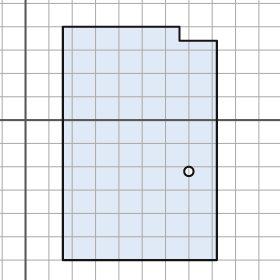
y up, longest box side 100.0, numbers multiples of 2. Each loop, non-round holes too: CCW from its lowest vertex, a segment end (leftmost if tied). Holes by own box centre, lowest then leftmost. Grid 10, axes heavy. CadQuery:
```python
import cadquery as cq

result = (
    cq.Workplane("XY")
    .moveTo(16.0, -60.0)
    .lineTo(82.0, -60.0)
    .lineTo(82.0, 34.0)
    .lineTo(66.0, 34.0)
    .lineTo(66.0, 40.0)
    .lineTo(16.0, 40.0)
    .close()
    .moveTo(70.0, -22.0)
    .circle(2.0)
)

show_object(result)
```